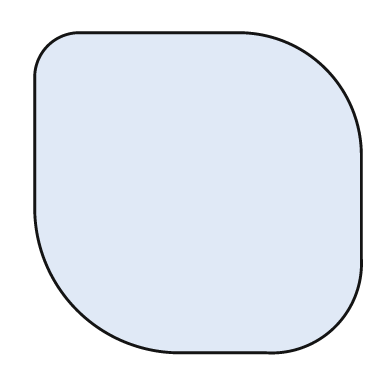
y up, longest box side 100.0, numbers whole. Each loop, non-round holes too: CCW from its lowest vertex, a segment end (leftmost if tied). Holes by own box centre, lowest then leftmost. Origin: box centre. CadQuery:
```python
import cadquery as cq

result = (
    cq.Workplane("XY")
    .moveTo(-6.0, -49.0)
    .lineTo(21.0, -49.0)
    .threePointArc((42.0, -41.0), (50.0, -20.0))
    .lineTo(50.0, 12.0)
    .threePointArc((39.0, 38.0), (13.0, 49.0))
    .lineTo(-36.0, 49.0)
    .threePointArc((-46.0, 45.0), (-50.0, 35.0))
    .lineTo(-50.0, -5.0)
    .threePointArc((-37.0, -36.0), (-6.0, -49.0))
    .close()
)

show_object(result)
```